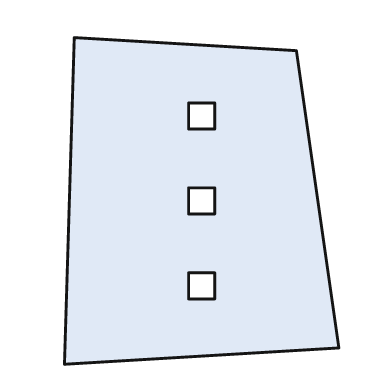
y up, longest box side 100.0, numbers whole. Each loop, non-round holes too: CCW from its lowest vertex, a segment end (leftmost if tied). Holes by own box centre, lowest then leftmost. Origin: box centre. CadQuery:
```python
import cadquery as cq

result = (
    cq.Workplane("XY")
    .moveTo(-42.0, -50.0)
    .lineTo(42.0, -45.0)
    .lineTo(29.0, 46.0)
    .lineTo(-39.0, 50.0)
    .close()
    .moveTo(-4.0, -30.0)
    .lineTo(4.0, -30.0)
    .lineTo(4.0, -22.0)
    .lineTo(-4.0, -22.0)
    .close()
    .moveTo(-4.0, -4.0)
    .lineTo(4.0, -4.0)
    .lineTo(4.0, 4.0)
    .lineTo(-4.0, 4.0)
    .close()
    .moveTo(-4.0, 22.0)
    .lineTo(4.0, 22.0)
    .lineTo(4.0, 30.0)
    .lineTo(-4.0, 30.0)
    .close()
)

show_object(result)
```